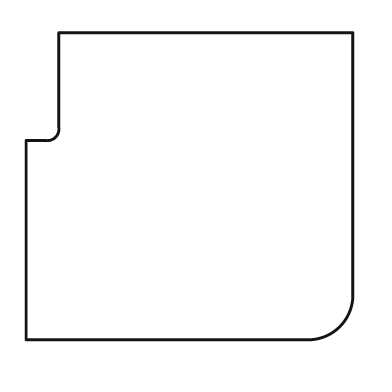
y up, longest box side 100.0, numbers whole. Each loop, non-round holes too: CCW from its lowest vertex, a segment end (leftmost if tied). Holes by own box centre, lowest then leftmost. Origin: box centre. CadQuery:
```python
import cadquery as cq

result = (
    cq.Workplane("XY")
    .moveTo(-50.0, -47.0)
    .lineTo(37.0, -47.0)
    .threePointArc((46.0, -43.0), (50.0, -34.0))
    .lineTo(50.0, 47.0)
    .lineTo(-40.0, 47.0)
    .lineTo(-40.0, 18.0)
    .threePointArc((-41.0, 15.0), (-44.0, 14.0))
    .lineTo(-50.0, 14.0)
    .close()
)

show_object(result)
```